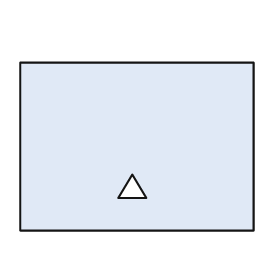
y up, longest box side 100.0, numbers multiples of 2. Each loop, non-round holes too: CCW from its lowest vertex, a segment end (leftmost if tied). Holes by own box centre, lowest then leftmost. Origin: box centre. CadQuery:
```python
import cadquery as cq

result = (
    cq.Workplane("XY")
    .moveTo(-50.0, -36.0)
    .lineTo(50.0, -36.0)
    .lineTo(50.0, 36.0)
    .lineTo(-50.0, 36.0)
    .close()
    .moveTo(-8.0, -22.0)
    .lineTo(4.0, -22.0)
    .lineTo(-2.0, -12.0)
    .close()
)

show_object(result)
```